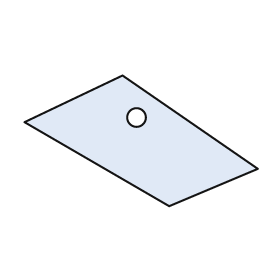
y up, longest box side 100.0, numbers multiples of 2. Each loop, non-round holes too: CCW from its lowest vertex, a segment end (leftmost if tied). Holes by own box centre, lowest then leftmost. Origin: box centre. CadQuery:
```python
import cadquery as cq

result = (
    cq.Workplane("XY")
    .moveTo(12.0, -28.0)
    .lineTo(50.0, -12.0)
    .lineTo(-8.0, 28.0)
    .lineTo(-50.0, 8.0)
    .close()
    .moveTo(-2.0, 10.0)
    .circle(4.0)
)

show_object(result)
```